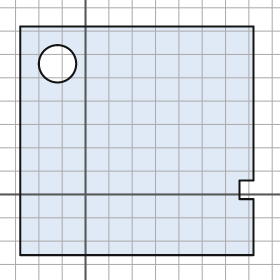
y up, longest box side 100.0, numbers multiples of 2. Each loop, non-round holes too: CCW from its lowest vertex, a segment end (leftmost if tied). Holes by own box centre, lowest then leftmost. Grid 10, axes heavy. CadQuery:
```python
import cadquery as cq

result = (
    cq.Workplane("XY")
    .moveTo(-28.0, -26.0)
    .lineTo(72.0, -26.0)
    .lineTo(72.0, -2.0)
    .lineTo(66.0, -2.0)
    .lineTo(66.0, 6.0)
    .lineTo(72.0, 6.0)
    .lineTo(72.0, 72.0)
    .lineTo(-28.0, 72.0)
    .close()
    .moveTo(-12.0, 56.0)
    .circle(8.0)
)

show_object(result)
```